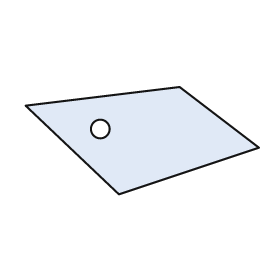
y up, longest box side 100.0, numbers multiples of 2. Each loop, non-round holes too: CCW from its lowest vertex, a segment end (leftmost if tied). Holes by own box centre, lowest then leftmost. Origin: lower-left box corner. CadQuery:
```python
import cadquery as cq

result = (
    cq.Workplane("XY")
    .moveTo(40.0, 0.0)
    .lineTo(100.0, 20.0)
    .lineTo(66.0, 46.0)
    .lineTo(0.0, 38.0)
    .close()
    .moveTo(32.0, 28.0)
    .circle(4.0)
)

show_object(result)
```